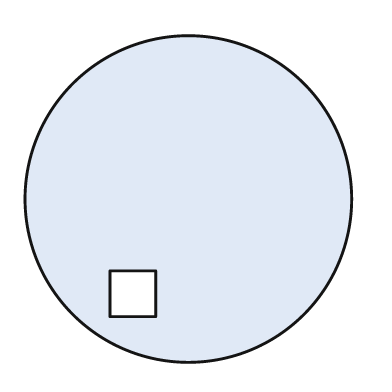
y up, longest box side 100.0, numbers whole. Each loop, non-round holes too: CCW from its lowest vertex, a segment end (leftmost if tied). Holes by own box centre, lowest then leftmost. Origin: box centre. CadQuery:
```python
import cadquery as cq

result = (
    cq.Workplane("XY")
    .moveTo(0.0, 0.0)
    .circle(50.0)
    .moveTo(-24.0, -36.0)
    .lineTo(-10.0, -36.0)
    .lineTo(-10.0, -22.0)
    .lineTo(-24.0, -22.0)
    .close()
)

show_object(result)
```